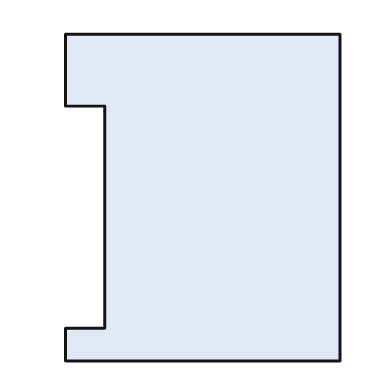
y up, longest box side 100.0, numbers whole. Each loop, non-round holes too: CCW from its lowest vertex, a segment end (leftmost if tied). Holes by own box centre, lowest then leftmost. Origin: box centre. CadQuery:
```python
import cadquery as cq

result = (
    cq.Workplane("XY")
    .moveTo(-42.0, -50.0)
    .lineTo(42.0, -50.0)
    .lineTo(42.0, 50.0)
    .lineTo(-42.0, 50.0)
    .lineTo(-42.0, 28.0)
    .lineTo(-30.0, 28.0)
    .lineTo(-30.0, -40.0)
    .lineTo(-42.0, -40.0)
    .close()
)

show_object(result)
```